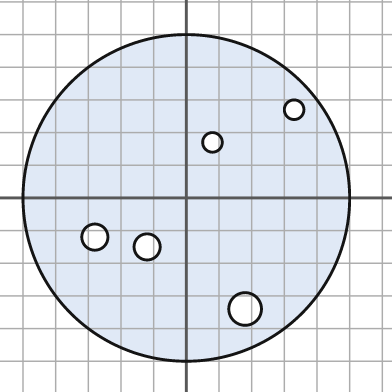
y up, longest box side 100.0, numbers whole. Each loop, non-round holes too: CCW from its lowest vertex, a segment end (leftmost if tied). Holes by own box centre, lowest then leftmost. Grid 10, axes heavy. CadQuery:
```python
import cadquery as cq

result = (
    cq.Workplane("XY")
    .moveTo(0.0, 0.0)
    .circle(50.0)
    .moveTo(18.0, -34.0)
    .circle(5.0)
    .moveTo(-12.0, -15.0)
    .circle(4.0)
    .moveTo(-28.0, -12.0)
    .circle(4.0)
    .moveTo(8.0, 17.0)
    .circle(3.0)
    .moveTo(33.0, 27.0)
    .circle(3.0)
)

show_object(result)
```